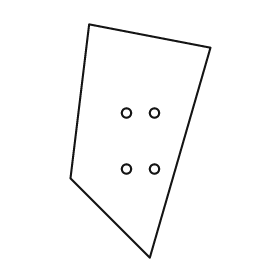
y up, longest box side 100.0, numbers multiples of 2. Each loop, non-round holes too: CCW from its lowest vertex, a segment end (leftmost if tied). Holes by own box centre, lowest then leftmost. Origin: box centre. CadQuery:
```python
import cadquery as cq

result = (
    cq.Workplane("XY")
    .moveTo(4.0, -50.0)
    .lineTo(30.0, 40.0)
    .lineTo(-22.0, 50.0)
    .lineTo(-30.0, -16.0)
    .close()
    .moveTo(-6.0, -12.0)
    .circle(2.0)
    .moveTo(6.0, -12.0)
    .circle(2.0)
    .moveTo(-6.0, 12.0)
    .circle(2.0)
    .moveTo(6.0, 12.0)
    .circle(2.0)
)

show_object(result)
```